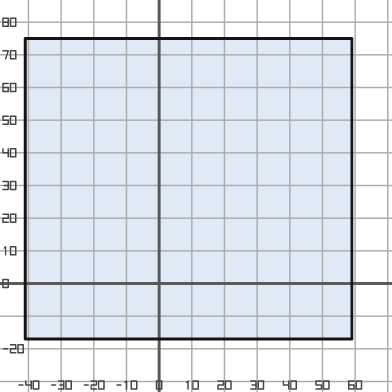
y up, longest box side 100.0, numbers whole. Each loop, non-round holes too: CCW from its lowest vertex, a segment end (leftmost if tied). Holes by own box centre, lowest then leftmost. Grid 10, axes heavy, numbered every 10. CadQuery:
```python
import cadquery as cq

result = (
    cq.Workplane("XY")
    .moveTo(-41.0, -17.0)
    .lineTo(59.0, -17.0)
    .lineTo(59.0, 75.0)
    .lineTo(-41.0, 75.0)
    .close()
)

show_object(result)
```